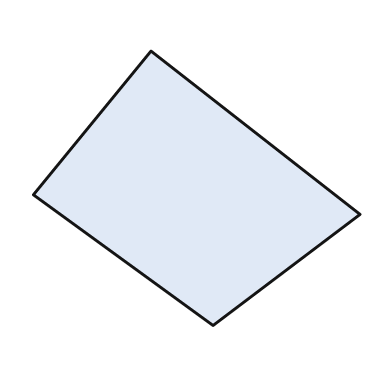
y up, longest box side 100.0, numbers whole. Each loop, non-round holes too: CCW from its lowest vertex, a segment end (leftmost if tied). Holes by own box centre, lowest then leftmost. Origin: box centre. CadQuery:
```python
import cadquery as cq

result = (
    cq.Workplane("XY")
    .moveTo(5.0, -42.0)
    .lineTo(50.0, -8.0)
    .lineTo(-14.0, 42.0)
    .lineTo(-50.0, -2.0)
    .close()
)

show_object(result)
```